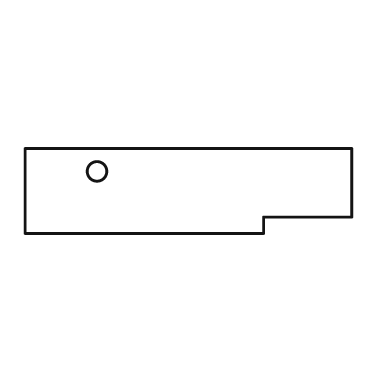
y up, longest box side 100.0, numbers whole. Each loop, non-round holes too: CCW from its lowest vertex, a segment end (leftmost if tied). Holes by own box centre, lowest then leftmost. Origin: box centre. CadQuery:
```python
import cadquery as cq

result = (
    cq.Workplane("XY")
    .moveTo(-50.0, -13.0)
    .lineTo(23.0, -13.0)
    .lineTo(23.0, -8.0)
    .lineTo(50.0, -8.0)
    .lineTo(50.0, 13.0)
    .lineTo(-50.0, 13.0)
    .close()
    .moveTo(-28.0, 6.0)
    .circle(3.0)
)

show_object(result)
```